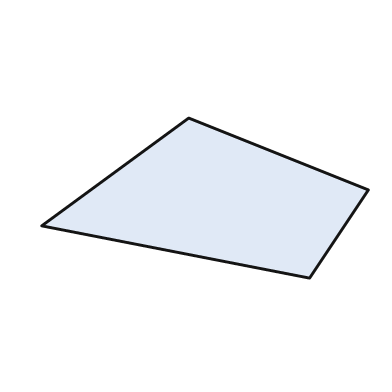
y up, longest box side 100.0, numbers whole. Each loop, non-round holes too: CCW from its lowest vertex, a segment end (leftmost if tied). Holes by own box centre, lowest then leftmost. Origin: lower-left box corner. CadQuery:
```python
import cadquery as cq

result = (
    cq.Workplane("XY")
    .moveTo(82.0, 0.0)
    .lineTo(100.0, 27.0)
    .lineTo(45.0, 49.0)
    .lineTo(0.0, 16.0)
    .close()
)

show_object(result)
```